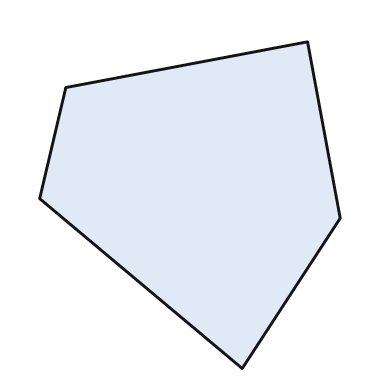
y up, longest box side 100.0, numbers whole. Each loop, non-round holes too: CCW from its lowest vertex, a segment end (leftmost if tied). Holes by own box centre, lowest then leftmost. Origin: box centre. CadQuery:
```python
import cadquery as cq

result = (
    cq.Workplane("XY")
    .moveTo(16.0, -50.0)
    .lineTo(46.0, -4.0)
    .lineTo(36.0, 50.0)
    .lineTo(-38.0, 36.0)
    .lineTo(-46.0, 2.0)
    .close()
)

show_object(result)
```